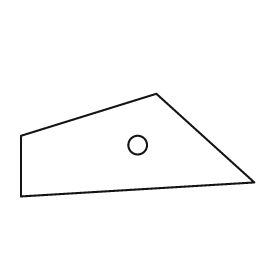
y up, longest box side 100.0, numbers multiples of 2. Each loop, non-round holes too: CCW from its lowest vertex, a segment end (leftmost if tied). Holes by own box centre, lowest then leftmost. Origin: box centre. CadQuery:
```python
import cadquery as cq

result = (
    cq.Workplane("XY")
    .moveTo(-50.0, -22.0)
    .lineTo(50.0, -16.0)
    .lineTo(8.0, 22.0)
    .lineTo(-50.0, 4.0)
    .close()
    .moveTo(0.0, 0.0)
    .circle(4.0)
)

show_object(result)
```